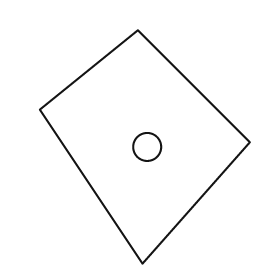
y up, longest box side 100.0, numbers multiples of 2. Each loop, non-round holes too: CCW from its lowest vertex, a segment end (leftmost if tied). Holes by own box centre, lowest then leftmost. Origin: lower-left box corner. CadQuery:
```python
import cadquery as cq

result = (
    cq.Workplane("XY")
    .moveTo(44.0, 0.0)
    .lineTo(90.0, 52.0)
    .lineTo(42.0, 100.0)
    .lineTo(0.0, 66.0)
    .close()
    .moveTo(46.0, 50.0)
    .circle(6.0)
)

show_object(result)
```